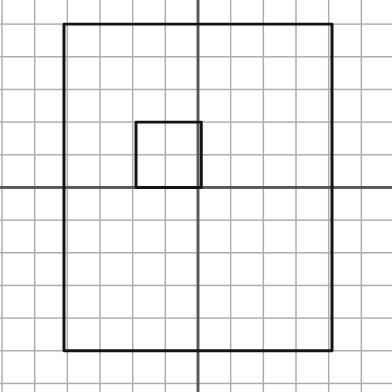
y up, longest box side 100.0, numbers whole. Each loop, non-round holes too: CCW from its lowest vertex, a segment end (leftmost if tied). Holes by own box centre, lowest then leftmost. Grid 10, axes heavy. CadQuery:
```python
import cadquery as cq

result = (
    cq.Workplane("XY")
    .moveTo(-41.0, -50.0)
    .lineTo(41.0, -50.0)
    .lineTo(41.0, 50.0)
    .lineTo(-41.0, 50.0)
    .close()
    .moveTo(-19.0, 0.0)
    .lineTo(1.0, 0.0)
    .lineTo(1.0, 20.0)
    .lineTo(-19.0, 20.0)
    .close()
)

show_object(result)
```